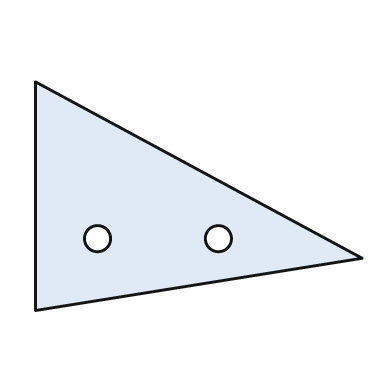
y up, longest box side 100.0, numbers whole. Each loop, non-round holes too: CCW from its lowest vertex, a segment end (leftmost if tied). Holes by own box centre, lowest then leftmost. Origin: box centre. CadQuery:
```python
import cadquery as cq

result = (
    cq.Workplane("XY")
    .moveTo(-50.0, -35.0)
    .lineTo(50.0, -19.0)
    .lineTo(-50.0, 35.0)
    .close()
    .moveTo(-31.0, -13.0)
    .circle(4.0)
    .moveTo(6.0, -13.0)
    .circle(4.0)
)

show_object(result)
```